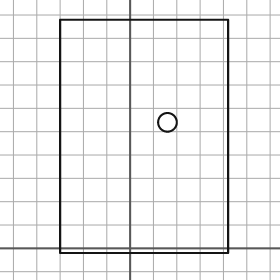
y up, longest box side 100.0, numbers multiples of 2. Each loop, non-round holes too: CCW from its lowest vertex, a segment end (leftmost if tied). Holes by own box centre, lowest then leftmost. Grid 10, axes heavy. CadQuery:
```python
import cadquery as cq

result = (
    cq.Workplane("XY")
    .moveTo(-30.0, -2.0)
    .lineTo(42.0, -2.0)
    .lineTo(42.0, 98.0)
    .lineTo(-30.0, 98.0)
    .close()
    .moveTo(16.0, 54.0)
    .circle(4.0)
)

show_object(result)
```